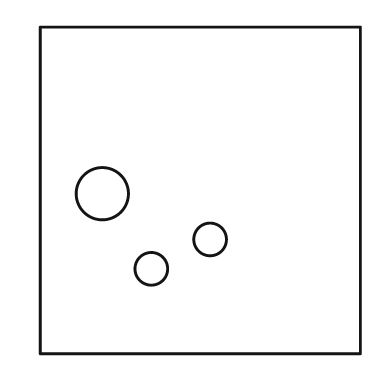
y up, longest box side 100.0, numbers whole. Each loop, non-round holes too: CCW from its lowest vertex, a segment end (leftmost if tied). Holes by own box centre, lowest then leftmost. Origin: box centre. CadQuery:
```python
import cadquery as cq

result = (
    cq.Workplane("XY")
    .moveTo(-49.0, -50.0)
    .lineTo(49.0, -50.0)
    .lineTo(49.0, 50.0)
    .lineTo(-49.0, 50.0)
    .close()
    .moveTo(-15.0, -24.0)
    .circle(5.0)
    .moveTo(3.0, -15.0)
    .circle(5.0)
    .moveTo(-30.0, -1.0)
    .circle(8.0)
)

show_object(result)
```